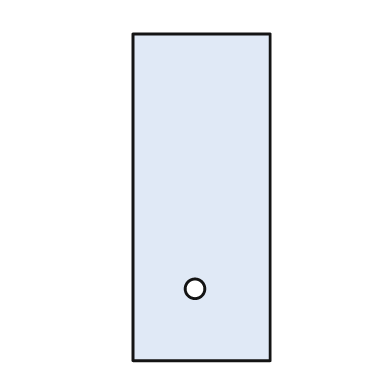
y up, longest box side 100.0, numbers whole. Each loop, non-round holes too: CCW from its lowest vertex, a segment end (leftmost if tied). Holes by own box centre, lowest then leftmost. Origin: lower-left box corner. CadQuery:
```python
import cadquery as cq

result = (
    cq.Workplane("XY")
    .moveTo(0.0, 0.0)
    .lineTo(42.0, 0.0)
    .lineTo(42.0, 100.0)
    .lineTo(0.0, 100.0)
    .close()
    .moveTo(19.0, 22.0)
    .circle(3.0)
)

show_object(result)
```